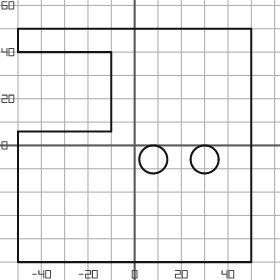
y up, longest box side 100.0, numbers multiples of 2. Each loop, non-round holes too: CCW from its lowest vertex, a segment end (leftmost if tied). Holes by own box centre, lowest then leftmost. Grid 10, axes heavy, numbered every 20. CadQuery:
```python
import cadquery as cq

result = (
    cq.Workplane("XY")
    .moveTo(-50.0, -50.0)
    .lineTo(50.0, -50.0)
    .lineTo(50.0, 50.0)
    .lineTo(-50.0, 50.0)
    .lineTo(-50.0, 40.0)
    .lineTo(-10.0, 40.0)
    .lineTo(-10.0, 6.0)
    .lineTo(-50.0, 6.0)
    .close()
    .moveTo(8.0, -6.0)
    .circle(6.0)
    .moveTo(30.0, -6.0)
    .circle(6.0)
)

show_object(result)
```